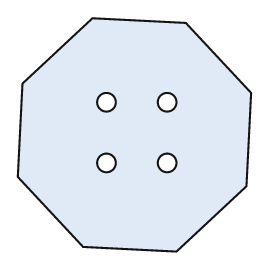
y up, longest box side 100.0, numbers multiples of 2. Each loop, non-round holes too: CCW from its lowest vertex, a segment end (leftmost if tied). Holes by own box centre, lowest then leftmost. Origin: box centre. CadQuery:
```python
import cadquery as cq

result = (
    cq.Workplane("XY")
    .moveTo(18.0, -50.0)
    .lineTo(48.0, -22.0)
    .lineTo(50.0, 18.0)
    .lineTo(22.0, 48.0)
    .lineTo(-18.0, 50.0)
    .lineTo(-48.0, 22.0)
    .lineTo(-50.0, -18.0)
    .lineTo(-22.0, -48.0)
    .close()
    .moveTo(-12.0, -12.0)
    .circle(4.0)
    .moveTo(14.0, -12.0)
    .circle(4.0)
    .moveTo(-12.0, 14.0)
    .circle(4.0)
    .moveTo(14.0, 14.0)
    .circle(4.0)
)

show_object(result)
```